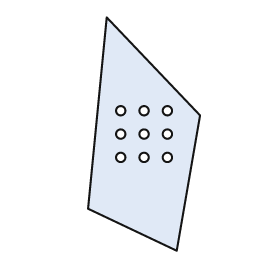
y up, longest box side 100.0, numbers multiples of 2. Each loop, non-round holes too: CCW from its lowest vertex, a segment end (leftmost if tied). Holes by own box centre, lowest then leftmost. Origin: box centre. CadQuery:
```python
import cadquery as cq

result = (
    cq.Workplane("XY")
    .moveTo(14.0, -50.0)
    .lineTo(24.0, 8.0)
    .lineTo(-16.0, 50.0)
    .lineTo(-24.0, -32.0)
    .close()
    .moveTo(-10.0, -10.0)
    .circle(2.0)
    .moveTo(0.0, -10.0)
    .circle(2.0)
    .moveTo(10.0, -10.0)
    .circle(2.0)
    .moveTo(-10.0, 0.0)
    .circle(2.0)
    .moveTo(0.0, 0.0)
    .circle(2.0)
    .moveTo(10.0, 0.0)
    .circle(2.0)
    .moveTo(-10.0, 10.0)
    .circle(2.0)
    .moveTo(0.0, 10.0)
    .circle(2.0)
    .moveTo(10.0, 10.0)
    .circle(2.0)
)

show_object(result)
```